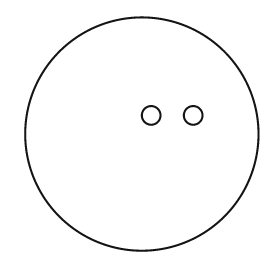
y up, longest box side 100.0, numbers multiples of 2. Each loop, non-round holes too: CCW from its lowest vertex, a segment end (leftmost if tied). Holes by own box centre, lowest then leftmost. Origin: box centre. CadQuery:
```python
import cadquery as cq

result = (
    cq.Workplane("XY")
    .moveTo(0.0, 0.0)
    .circle(50.0)
    .moveTo(4.0, 8.0)
    .circle(4.0)
    .moveTo(22.0, 8.0)
    .circle(4.0)
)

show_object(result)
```